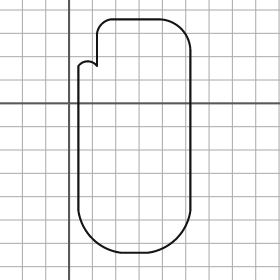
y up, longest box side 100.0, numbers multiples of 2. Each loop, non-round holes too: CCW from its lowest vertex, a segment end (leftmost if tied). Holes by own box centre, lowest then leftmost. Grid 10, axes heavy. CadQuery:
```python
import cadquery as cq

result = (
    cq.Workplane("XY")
    .moveTo(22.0, -64.0)
    .lineTo(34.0, -64.0)
    .threePointArc((46.0, -58.0), (52.0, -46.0))
    .lineTo(52.0, 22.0)
    .threePointArc((48.0, 32.0), (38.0, 36.0))
    .lineTo(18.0, 36.0)
    .threePointArc((14.0, 34.0), (12.0, 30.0))
    .lineTo(12.0, 16.0)
    .threePointArc((8.0, 18.0), (4.0, 16.0))
    .lineTo(4.0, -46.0)
    .threePointArc((10.0, -58.0), (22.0, -64.0))
    .close()
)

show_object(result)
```